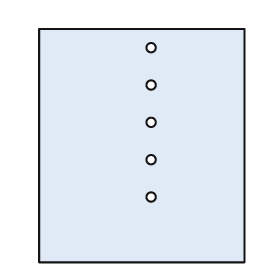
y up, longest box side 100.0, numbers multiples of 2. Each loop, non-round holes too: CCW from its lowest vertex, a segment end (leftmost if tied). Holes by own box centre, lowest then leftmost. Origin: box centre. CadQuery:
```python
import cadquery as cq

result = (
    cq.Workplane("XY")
    .moveTo(-44.0, -50.0)
    .lineTo(44.0, -50.0)
    .lineTo(44.0, 50.0)
    .lineTo(-44.0, 50.0)
    .close()
    .moveTo(4.0, -22.0)
    .circle(2.0)
    .moveTo(4.0, -6.0)
    .circle(2.0)
    .moveTo(4.0, 10.0)
    .circle(2.0)
    .moveTo(4.0, 26.0)
    .circle(2.0)
    .moveTo(4.0, 42.0)
    .circle(2.0)
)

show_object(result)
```